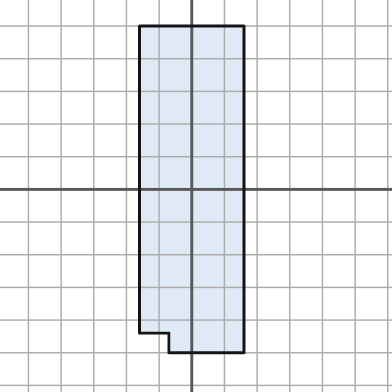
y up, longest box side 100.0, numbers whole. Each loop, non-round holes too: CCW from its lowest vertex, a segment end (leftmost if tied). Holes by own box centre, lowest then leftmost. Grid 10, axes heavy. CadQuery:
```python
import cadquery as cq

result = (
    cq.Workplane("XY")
    .moveTo(-7.0, -50.0)
    .lineTo(16.0, -50.0)
    .lineTo(16.0, 50.0)
    .lineTo(-16.0, 50.0)
    .lineTo(-16.0, -44.0)
    .lineTo(-7.0, -44.0)
    .close()
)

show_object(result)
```